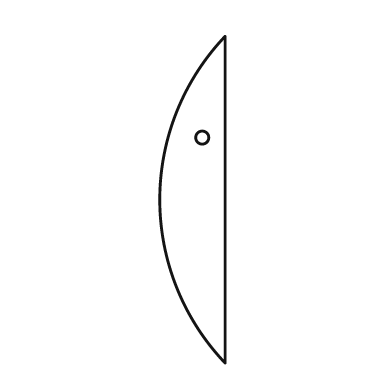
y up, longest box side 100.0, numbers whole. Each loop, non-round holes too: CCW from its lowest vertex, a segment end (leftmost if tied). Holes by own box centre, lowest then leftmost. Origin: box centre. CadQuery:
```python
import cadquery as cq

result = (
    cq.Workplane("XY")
    .moveTo(10.0, -50.0)
    .lineTo(10.0, 50.0)
    .threePointArc((-10.0, 0.0), (10.0, -50.0))
    .close()
    .moveTo(3.0, 19.0)
    .circle(2.0)
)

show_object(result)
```